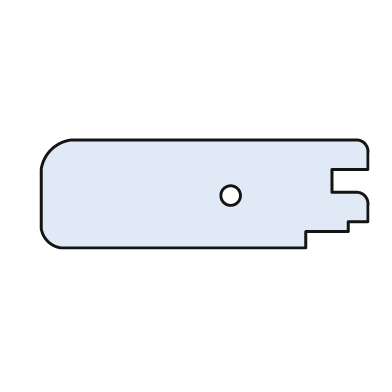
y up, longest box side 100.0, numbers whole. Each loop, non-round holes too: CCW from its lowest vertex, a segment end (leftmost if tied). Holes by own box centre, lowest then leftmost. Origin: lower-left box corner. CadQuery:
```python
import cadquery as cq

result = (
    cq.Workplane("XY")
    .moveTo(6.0, 0.0)
    .lineTo(81.0, 0.0)
    .lineTo(81.0, 5.0)
    .lineTo(94.0, 5.0)
    .lineTo(94.0, 8.0)
    .lineTo(100.0, 8.0)
    .lineTo(100.0, 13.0)
    .threePointArc((99.0, 16.0), (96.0, 17.0))
    .lineTo(89.0, 17.0)
    .lineTo(89.0, 24.0)
    .lineTo(100.0, 24.0)
    .lineTo(100.0, 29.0)
    .threePointArc((99.0, 32.0), (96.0, 33.0))
    .lineTo(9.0, 33.0)
    .threePointArc((3.0, 30.0), (0.0, 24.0))
    .lineTo(0.0, 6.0)
    .threePointArc((2.0, 2.0), (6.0, 0.0))
    .close()
    .moveTo(58.0, 16.0)
    .circle(3.0)
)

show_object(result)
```